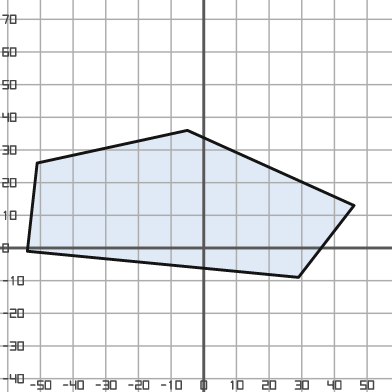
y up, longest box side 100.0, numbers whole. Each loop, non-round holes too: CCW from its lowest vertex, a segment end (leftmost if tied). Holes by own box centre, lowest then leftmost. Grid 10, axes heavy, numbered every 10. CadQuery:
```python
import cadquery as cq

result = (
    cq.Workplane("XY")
    .moveTo(29.0, -9.0)
    .lineTo(46.0, 13.0)
    .lineTo(-5.0, 36.0)
    .lineTo(-51.0, 26.0)
    .lineTo(-54.0, -1.0)
    .close()
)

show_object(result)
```